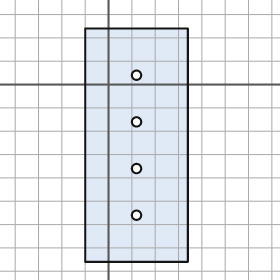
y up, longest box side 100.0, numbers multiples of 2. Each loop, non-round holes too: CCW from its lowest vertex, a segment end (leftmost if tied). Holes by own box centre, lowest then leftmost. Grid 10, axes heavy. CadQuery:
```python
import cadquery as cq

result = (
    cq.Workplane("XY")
    .moveTo(-10.0, -76.0)
    .lineTo(34.0, -76.0)
    .lineTo(34.0, 24.0)
    .lineTo(-10.0, 24.0)
    .close()
    .moveTo(12.0, -56.0)
    .circle(2.0)
    .moveTo(12.0, -36.0)
    .circle(2.0)
    .moveTo(12.0, -16.0)
    .circle(2.0)
    .moveTo(12.0, 4.0)
    .circle(2.0)
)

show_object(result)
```